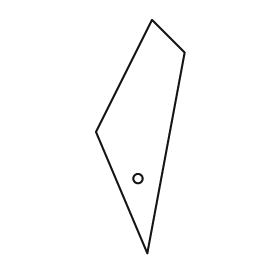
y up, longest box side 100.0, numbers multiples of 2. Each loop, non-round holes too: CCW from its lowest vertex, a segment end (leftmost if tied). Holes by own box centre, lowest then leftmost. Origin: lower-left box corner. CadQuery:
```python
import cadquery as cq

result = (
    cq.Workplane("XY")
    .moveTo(22.0, 0.0)
    .lineTo(38.0, 86.0)
    .lineTo(24.0, 100.0)
    .lineTo(0.0, 52.0)
    .close()
    .moveTo(18.0, 32.0)
    .circle(2.0)
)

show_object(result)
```